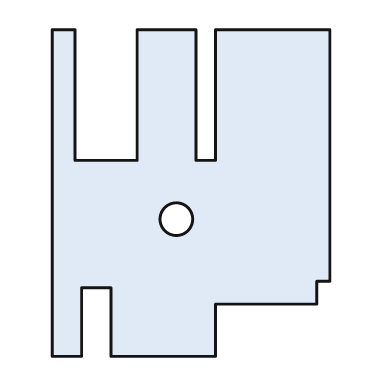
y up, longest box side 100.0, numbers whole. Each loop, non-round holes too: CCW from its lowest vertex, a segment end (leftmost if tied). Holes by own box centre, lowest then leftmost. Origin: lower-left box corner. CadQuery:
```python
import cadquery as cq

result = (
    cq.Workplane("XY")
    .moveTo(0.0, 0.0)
    .lineTo(9.0, 0.0)
    .lineTo(9.0, 21.0)
    .lineTo(18.0, 21.0)
    .lineTo(18.0, 0.0)
    .lineTo(50.0, 0.0)
    .lineTo(50.0, 16.0)
    .lineTo(81.0, 16.0)
    .lineTo(81.0, 23.0)
    .lineTo(85.0, 23.0)
    .lineTo(85.0, 100.0)
    .lineTo(50.0, 100.0)
    .lineTo(50.0, 60.0)
    .lineTo(44.0, 60.0)
    .lineTo(44.0, 100.0)
    .lineTo(26.0, 100.0)
    .lineTo(26.0, 60.0)
    .lineTo(7.0, 60.0)
    .lineTo(7.0, 100.0)
    .lineTo(0.0, 100.0)
    .close()
    .moveTo(38.0, 42.0)
    .circle(5.0)
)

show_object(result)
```